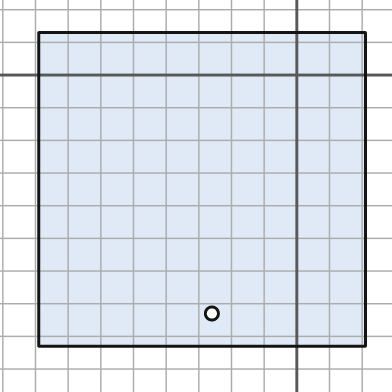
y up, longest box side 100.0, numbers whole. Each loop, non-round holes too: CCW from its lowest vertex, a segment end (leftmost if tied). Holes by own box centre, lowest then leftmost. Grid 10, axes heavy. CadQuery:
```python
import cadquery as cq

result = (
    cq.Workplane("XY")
    .moveTo(-79.0, -83.0)
    .lineTo(21.0, -83.0)
    .lineTo(21.0, 13.0)
    .lineTo(-79.0, 13.0)
    .close()
    .moveTo(-26.0, -73.0)
    .circle(2.0)
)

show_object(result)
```